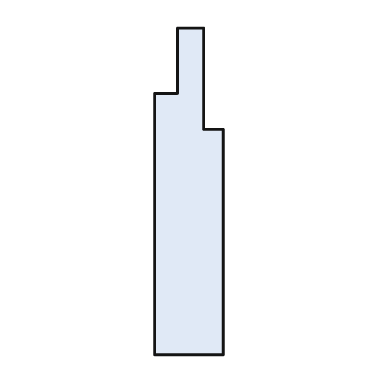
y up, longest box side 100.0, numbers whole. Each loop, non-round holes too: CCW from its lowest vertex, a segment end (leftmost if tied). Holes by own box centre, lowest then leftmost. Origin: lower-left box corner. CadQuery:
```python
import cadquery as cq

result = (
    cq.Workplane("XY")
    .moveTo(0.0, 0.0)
    .lineTo(21.0, 0.0)
    .lineTo(21.0, 69.0)
    .lineTo(15.0, 69.0)
    .lineTo(15.0, 100.0)
    .lineTo(7.0, 100.0)
    .lineTo(7.0, 80.0)
    .lineTo(0.0, 80.0)
    .close()
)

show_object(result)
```